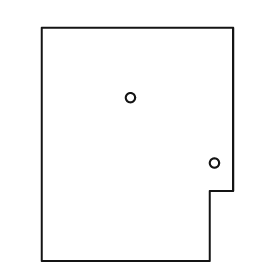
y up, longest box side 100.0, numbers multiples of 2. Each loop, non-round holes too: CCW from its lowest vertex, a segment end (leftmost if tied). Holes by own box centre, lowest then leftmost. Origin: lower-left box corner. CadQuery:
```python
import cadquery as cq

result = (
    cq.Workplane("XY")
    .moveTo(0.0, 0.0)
    .lineTo(72.0, 0.0)
    .lineTo(72.0, 30.0)
    .lineTo(82.0, 30.0)
    .lineTo(82.0, 100.0)
    .lineTo(0.0, 100.0)
    .close()
    .moveTo(74.0, 42.0)
    .circle(2.0)
    .moveTo(38.0, 70.0)
    .circle(2.0)
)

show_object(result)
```